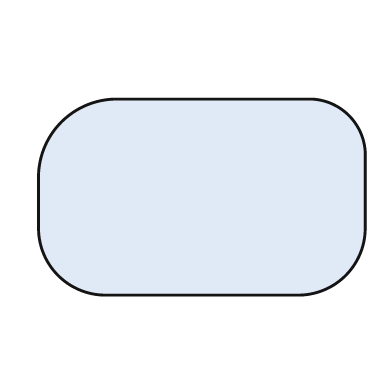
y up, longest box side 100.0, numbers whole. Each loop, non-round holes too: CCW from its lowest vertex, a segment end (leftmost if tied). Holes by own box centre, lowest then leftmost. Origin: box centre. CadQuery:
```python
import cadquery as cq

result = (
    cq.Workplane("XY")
    .moveTo(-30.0, -30.0)
    .lineTo(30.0, -30.0)
    .threePointArc((44.0, -24.0), (50.0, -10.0))
    .lineTo(50.0, 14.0)
    .threePointArc((45.0, 25.0), (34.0, 30.0))
    .lineTo(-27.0, 30.0)
    .threePointArc((-43.0, 23.0), (-50.0, 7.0))
    .lineTo(-50.0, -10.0)
    .threePointArc((-44.0, -24.0), (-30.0, -30.0))
    .close()
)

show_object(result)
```